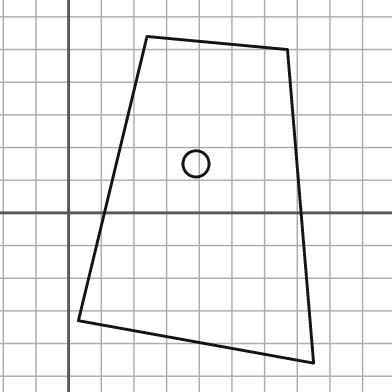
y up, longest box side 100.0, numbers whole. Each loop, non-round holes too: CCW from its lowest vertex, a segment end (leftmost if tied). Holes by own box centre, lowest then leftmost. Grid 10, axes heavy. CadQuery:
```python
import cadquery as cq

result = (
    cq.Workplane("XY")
    .moveTo(75.0, -46.0)
    .lineTo(67.0, 50.0)
    .lineTo(24.0, 54.0)
    .lineTo(3.0, -33.0)
    .close()
    .moveTo(39.0, 15.0)
    .circle(4.0)
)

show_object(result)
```